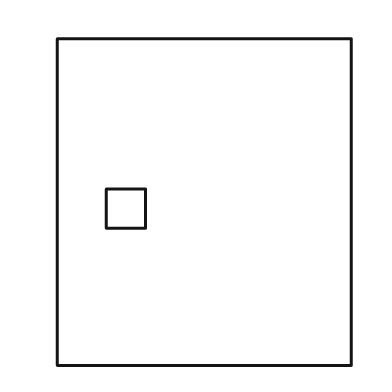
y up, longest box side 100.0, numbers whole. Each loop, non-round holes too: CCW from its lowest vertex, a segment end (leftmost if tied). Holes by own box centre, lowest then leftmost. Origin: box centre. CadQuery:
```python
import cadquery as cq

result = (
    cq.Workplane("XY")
    .moveTo(-45.0, -50.0)
    .lineTo(45.0, -50.0)
    .lineTo(45.0, 50.0)
    .lineTo(-45.0, 50.0)
    .close()
    .moveTo(-30.0, -8.0)
    .lineTo(-18.0, -8.0)
    .lineTo(-18.0, 4.0)
    .lineTo(-30.0, 4.0)
    .close()
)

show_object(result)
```